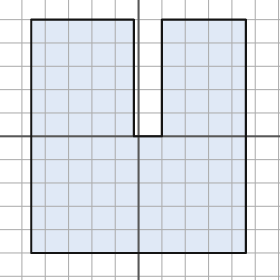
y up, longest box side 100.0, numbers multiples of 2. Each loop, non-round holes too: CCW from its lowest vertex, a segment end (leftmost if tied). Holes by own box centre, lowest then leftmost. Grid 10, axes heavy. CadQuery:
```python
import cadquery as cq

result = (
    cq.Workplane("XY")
    .moveTo(-46.0, -50.0)
    .lineTo(46.0, -50.0)
    .lineTo(46.0, 50.0)
    .lineTo(10.0, 50.0)
    .lineTo(10.0, 0.0)
    .lineTo(-2.0, 0.0)
    .lineTo(-2.0, 50.0)
    .lineTo(-46.0, 50.0)
    .close()
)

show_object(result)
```